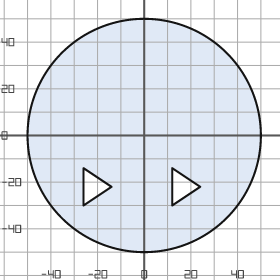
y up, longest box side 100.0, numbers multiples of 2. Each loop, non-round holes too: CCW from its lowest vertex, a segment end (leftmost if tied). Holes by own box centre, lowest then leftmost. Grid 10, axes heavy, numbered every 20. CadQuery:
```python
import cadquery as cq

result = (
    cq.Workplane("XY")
    .moveTo(0.0, 0.0)
    .circle(50.0)
    .moveTo(-26.0, -30.0)
    .lineTo(-14.0, -22.0)
    .lineTo(-26.0, -14.0)
    .close()
    .moveTo(12.0, -30.0)
    .lineTo(24.0, -22.0)
    .lineTo(12.0, -14.0)
    .close()
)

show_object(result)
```